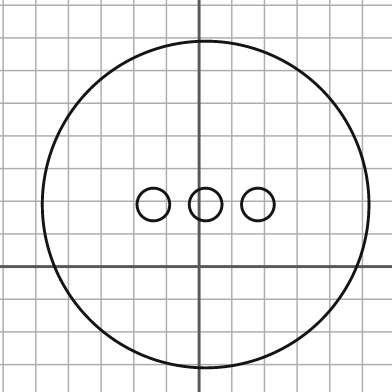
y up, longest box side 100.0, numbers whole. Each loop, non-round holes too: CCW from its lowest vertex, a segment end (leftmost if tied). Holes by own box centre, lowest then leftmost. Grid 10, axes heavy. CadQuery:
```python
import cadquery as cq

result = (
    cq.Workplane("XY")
    .moveTo(2.0, 19.0)
    .circle(50.0)
    .moveTo(-14.0, 19.0)
    .circle(5.0)
    .moveTo(2.0, 19.0)
    .circle(5.0)
    .moveTo(18.0, 19.0)
    .circle(5.0)
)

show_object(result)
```